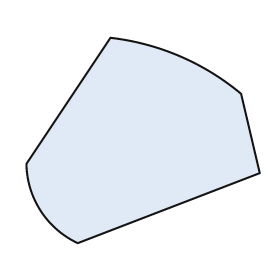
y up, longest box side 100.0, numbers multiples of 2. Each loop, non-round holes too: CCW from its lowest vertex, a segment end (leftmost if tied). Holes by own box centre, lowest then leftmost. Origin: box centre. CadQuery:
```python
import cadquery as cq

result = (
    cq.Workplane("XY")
    .moveTo(-28.0, -44.0)
    .lineTo(50.0, -14.0)
    .lineTo(42.0, 20.0)
    .threePointArc((16.0, 36.0), (-14.0, 44.0))
    .lineTo(-50.0, -10.0)
    .threePointArc((-44.0, -30.0), (-28.0, -44.0))
    .close()
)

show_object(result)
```